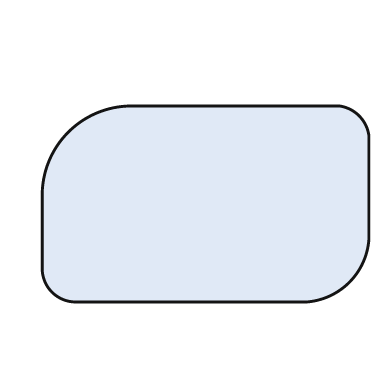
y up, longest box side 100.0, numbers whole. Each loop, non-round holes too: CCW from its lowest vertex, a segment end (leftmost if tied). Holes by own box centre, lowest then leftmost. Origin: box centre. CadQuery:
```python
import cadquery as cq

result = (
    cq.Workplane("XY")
    .moveTo(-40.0, -30.0)
    .lineTo(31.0, -30.0)
    .threePointArc((44.0, -24.0), (50.0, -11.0))
    .lineTo(50.0, 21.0)
    .threePointArc((47.0, 27.0), (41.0, 30.0))
    .lineTo(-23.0, 30.0)
    .threePointArc((-42.0, 22.0), (-50.0, 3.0))
    .lineTo(-50.0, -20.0)
    .threePointArc((-47.0, -27.0), (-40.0, -30.0))
    .close()
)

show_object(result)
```